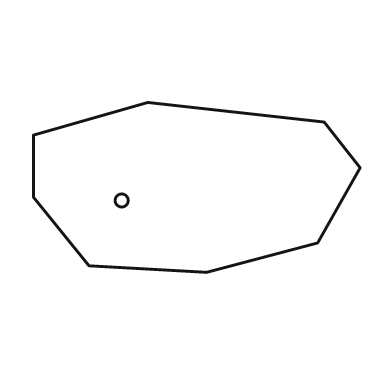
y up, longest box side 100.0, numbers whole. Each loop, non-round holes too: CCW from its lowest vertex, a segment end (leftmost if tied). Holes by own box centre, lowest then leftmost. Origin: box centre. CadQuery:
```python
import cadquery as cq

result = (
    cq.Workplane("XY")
    .moveTo(3.0, -26.0)
    .lineTo(37.0, -17.0)
    .lineTo(50.0, 6.0)
    .lineTo(39.0, 20.0)
    .lineTo(-15.0, 26.0)
    .lineTo(-50.0, 16.0)
    .lineTo(-50.0, -3.0)
    .lineTo(-33.0, -24.0)
    .close()
    .moveTo(-23.0, -4.0)
    .circle(2.0)
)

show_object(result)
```